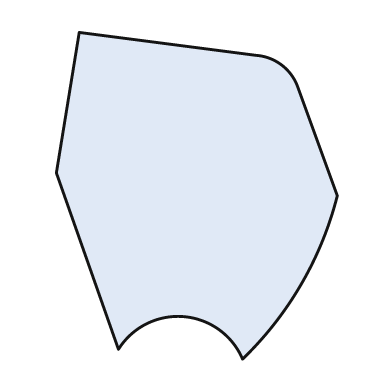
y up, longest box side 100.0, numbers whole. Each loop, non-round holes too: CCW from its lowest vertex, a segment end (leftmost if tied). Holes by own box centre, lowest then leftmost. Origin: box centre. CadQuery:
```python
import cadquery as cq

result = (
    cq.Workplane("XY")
    .moveTo(14.0, -50.0)
    .threePointArc((32.0, -27.0), (43.0, 0.0))
    .lineTo(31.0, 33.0)
    .threePointArc((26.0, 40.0), (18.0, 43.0))
    .lineTo(-36.0, 50.0)
    .lineTo(-43.0, 7.0)
    .lineTo(-24.0, -47.0)
    .threePointArc((-4.0, -37.0), (14.0, -50.0))
    .close()
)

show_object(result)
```